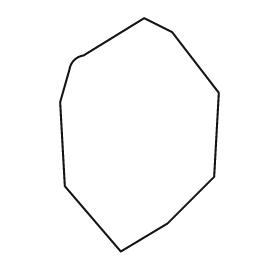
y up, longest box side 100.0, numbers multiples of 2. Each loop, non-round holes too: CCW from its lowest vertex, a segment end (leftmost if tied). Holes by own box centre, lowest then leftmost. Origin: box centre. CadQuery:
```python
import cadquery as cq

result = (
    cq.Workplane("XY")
    .moveTo(-8.0, -50.0)
    .lineTo(12.0, -38.0)
    .lineTo(32.0, -18.0)
    .lineTo(34.0, 18.0)
    .lineTo(14.0, 44.0)
    .lineTo(2.0, 50.0)
    .lineTo(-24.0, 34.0)
    .threePointArc((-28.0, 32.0), (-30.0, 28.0))
    .lineTo(-34.0, 14.0)
    .lineTo(-32.0, -22.0)
    .close()
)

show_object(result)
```